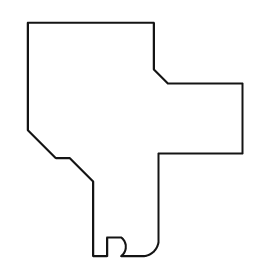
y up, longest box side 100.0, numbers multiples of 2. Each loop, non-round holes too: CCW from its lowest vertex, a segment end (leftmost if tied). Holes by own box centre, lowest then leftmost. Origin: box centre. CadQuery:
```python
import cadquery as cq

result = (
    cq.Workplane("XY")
    .moveTo(-18.0, -50.0)
    .lineTo(-12.0, -50.0)
    .lineTo(-12.0, -42.0)
    .lineTo(-6.0, -42.0)
    .threePointArc((-4.0, -46.0), (-6.0, -50.0))
    .lineTo(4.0, -50.0)
    .threePointArc((8.0, -48.0), (10.0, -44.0))
    .lineTo(10.0, -6.0)
    .lineTo(46.0, -6.0)
    .lineTo(46.0, 24.0)
    .lineTo(14.0, 24.0)
    .lineTo(8.0, 30.0)
    .lineTo(8.0, 50.0)
    .lineTo(-46.0, 50.0)
    .lineTo(-46.0, 4.0)
    .lineTo(-34.0, -8.0)
    .lineTo(-28.0, -8.0)
    .lineTo(-18.0, -18.0)
    .close()
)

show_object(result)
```